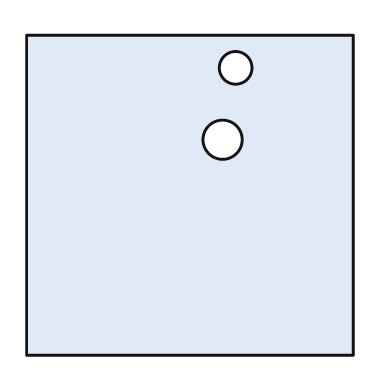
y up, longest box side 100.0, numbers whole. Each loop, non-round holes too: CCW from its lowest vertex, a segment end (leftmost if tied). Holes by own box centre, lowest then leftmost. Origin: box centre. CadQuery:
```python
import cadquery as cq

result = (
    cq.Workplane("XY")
    .moveTo(-50.0, -49.0)
    .lineTo(50.0, -49.0)
    .lineTo(50.0, 49.0)
    .lineTo(-50.0, 49.0)
    .close()
    .moveTo(10.0, 17.0)
    .circle(6.0)
    .moveTo(14.0, 39.0)
    .circle(5.0)
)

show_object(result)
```